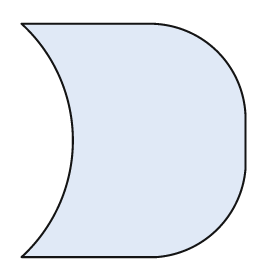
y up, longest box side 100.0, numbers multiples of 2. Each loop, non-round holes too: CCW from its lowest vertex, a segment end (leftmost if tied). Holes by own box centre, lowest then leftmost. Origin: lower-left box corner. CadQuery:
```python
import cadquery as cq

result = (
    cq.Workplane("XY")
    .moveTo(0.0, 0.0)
    .lineTo(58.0, 0.0)
    .threePointArc((84.0, 12.0), (96.0, 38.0))
    .lineTo(96.0, 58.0)
    .threePointArc((84.0, 88.0), (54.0, 100.0))
    .lineTo(0.0, 100.0)
    .threePointArc((22.0, 50.0), (0.0, 0.0))
    .close()
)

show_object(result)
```